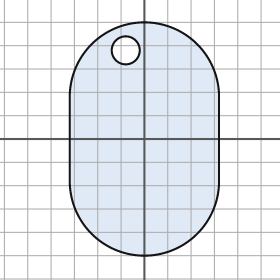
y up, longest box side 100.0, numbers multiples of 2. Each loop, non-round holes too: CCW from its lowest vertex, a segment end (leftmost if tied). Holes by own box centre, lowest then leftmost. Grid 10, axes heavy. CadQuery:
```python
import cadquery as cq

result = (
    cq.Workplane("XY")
    .moveTo(-32.0, -18.0)
    .threePointArc((0.0, -50.0), (32.0, -18.0))
    .lineTo(32.0, 18.0)
    .threePointArc((0.0, 50.0), (-32.0, 18.0))
    .close()
    .moveTo(-8.0, 38.0)
    .circle(6.0)
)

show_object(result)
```